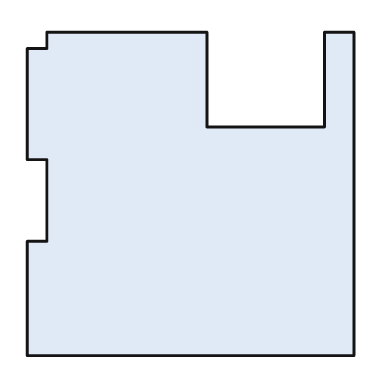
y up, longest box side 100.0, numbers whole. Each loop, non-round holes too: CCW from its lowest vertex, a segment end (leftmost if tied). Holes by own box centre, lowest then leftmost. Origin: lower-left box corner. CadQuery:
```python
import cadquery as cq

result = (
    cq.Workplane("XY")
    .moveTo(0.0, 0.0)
    .lineTo(100.0, 0.0)
    .lineTo(100.0, 99.0)
    .lineTo(91.0, 99.0)
    .lineTo(91.0, 70.0)
    .lineTo(55.0, 70.0)
    .lineTo(55.0, 99.0)
    .lineTo(6.0, 99.0)
    .lineTo(6.0, 94.0)
    .lineTo(0.0, 94.0)
    .lineTo(0.0, 60.0)
    .lineTo(6.0, 60.0)
    .lineTo(6.0, 35.0)
    .lineTo(0.0, 35.0)
    .close()
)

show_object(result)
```